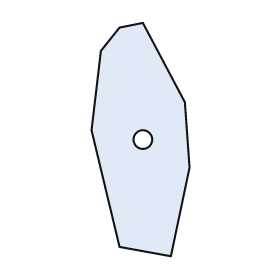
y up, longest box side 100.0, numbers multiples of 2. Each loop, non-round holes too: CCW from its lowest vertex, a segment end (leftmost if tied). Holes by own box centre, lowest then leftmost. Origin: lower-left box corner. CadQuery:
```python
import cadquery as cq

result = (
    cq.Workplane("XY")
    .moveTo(34.0, 0.0)
    .lineTo(42.0, 38.0)
    .lineTo(40.0, 66.0)
    .lineTo(22.0, 100.0)
    .lineTo(12.0, 98.0)
    .lineTo(4.0, 88.0)
    .lineTo(0.0, 54.0)
    .lineTo(12.0, 4.0)
    .close()
    .moveTo(22.0, 50.0)
    .circle(4.0)
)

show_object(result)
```